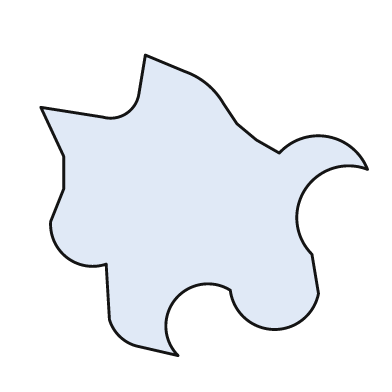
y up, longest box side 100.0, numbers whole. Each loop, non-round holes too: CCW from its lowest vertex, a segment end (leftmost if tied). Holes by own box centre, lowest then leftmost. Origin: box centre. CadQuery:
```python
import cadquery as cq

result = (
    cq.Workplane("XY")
    .moveTo(-8.0, -46.0)
    .threePointArc((-9.0, -29.0), (8.0, -26.0))
    .threePointArc((21.0, -38.0), (35.0, -27.0))
    .lineTo(33.0, -15.0)
    .threePointArc((31.0, 5.0), (50.0, 11.0))
    .threePointArc((38.0, 21.0), (23.0, 16.0))
    .lineTo(16.0, 20.0)
    .lineTo(10.0, 25.0)
    .lineTo(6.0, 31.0)
    .threePointArc((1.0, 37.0), (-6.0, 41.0))
    .lineTo(-18.0, 46.0)
    .lineTo(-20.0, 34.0)
    .threePointArc((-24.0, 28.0), (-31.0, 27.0))
    .lineTo(-50.0, 30.0)
    .lineTo(-43.0, 15.0)
    .lineTo(-43.0, 5.0)
    .lineTo(-47.0, -5.0)
    .threePointArc((-42.0, -16.0), (-30.0, -18.0))
    .lineTo(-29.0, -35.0)
    .threePointArc((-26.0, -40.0), (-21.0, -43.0))
    .close()
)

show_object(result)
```